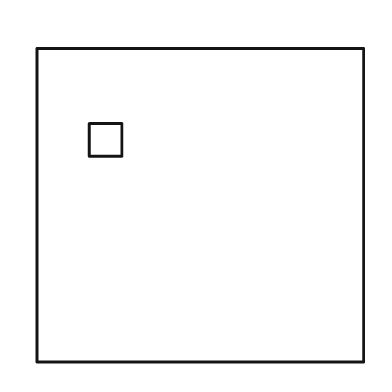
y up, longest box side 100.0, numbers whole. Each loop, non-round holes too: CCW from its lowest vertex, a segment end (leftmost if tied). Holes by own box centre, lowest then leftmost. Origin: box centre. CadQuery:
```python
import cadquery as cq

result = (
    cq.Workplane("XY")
    .moveTo(-50.0, -48.0)
    .lineTo(50.0, -48.0)
    .lineTo(50.0, 48.0)
    .lineTo(-50.0, 48.0)
    .close()
    .moveTo(-34.0, 15.0)
    .lineTo(-24.0, 15.0)
    .lineTo(-24.0, 25.0)
    .lineTo(-34.0, 25.0)
    .close()
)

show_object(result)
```